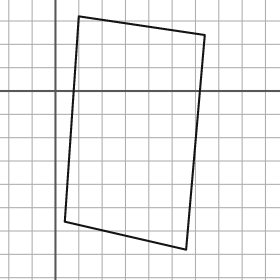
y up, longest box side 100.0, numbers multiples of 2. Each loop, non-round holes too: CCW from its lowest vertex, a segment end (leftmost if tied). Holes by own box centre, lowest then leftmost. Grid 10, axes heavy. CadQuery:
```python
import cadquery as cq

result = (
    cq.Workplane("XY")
    .moveTo(56.0, -68.0)
    .lineTo(64.0, 24.0)
    .lineTo(10.0, 32.0)
    .lineTo(4.0, -56.0)
    .close()
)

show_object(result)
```